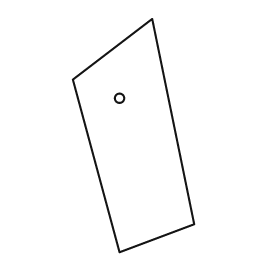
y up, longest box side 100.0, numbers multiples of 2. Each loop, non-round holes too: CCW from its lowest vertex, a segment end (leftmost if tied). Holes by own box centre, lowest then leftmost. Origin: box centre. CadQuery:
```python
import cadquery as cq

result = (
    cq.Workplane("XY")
    .moveTo(-6.0, -50.0)
    .lineTo(26.0, -38.0)
    .lineTo(8.0, 50.0)
    .lineTo(-26.0, 24.0)
    .close()
    .moveTo(-6.0, 16.0)
    .circle(2.0)
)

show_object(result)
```